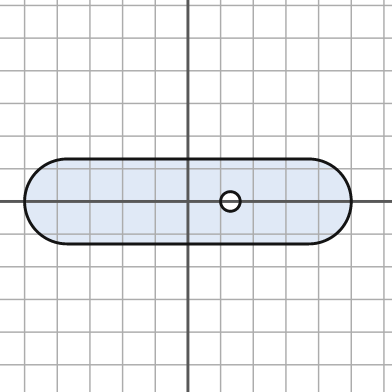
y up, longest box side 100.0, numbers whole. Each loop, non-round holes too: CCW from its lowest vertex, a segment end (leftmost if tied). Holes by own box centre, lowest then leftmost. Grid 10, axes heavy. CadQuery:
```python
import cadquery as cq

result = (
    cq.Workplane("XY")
    .moveTo(-37.0, -13.0)
    .lineTo(37.0, -13.0)
    .threePointArc((50.0, 0.0), (37.0, 13.0))
    .lineTo(-37.0, 13.0)
    .threePointArc((-50.0, 0.0), (-37.0, -13.0))
    .close()
    .moveTo(13.0, 0.0)
    .circle(3.0)
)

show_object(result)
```